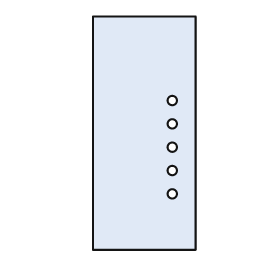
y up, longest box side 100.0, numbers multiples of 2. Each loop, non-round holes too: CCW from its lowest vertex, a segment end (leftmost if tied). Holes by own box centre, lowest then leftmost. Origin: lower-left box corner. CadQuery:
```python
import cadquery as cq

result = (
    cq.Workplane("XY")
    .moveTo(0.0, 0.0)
    .lineTo(44.0, 0.0)
    .lineTo(44.0, 100.0)
    .lineTo(0.0, 100.0)
    .close()
    .moveTo(34.0, 24.0)
    .circle(2.0)
    .moveTo(34.0, 34.0)
    .circle(2.0)
    .moveTo(34.0, 44.0)
    .circle(2.0)
    .moveTo(34.0, 54.0)
    .circle(2.0)
    .moveTo(34.0, 64.0)
    .circle(2.0)
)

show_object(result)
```